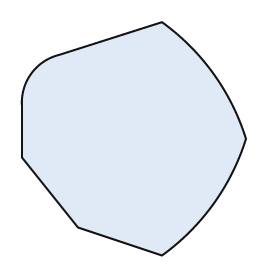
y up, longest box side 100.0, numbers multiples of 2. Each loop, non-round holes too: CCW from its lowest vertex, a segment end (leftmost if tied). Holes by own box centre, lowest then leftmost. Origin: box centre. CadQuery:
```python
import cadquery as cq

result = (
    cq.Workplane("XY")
    .moveTo(12.0, -50.0)
    .threePointArc((34.0, -28.0), (48.0, 0.0))
    .threePointArc((34.0, 28.0), (12.0, 50.0))
    .lineTo(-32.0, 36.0)
    .threePointArc((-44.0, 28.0), (-48.0, 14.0))
    .lineTo(-48.0, -8.0)
    .lineTo(-24.0, -38.0)
    .close()
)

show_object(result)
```